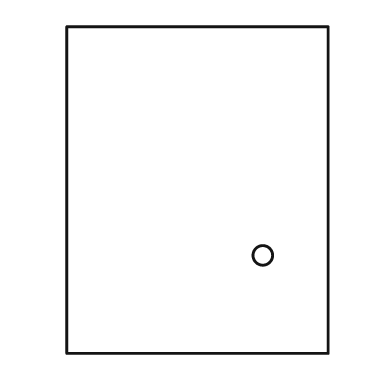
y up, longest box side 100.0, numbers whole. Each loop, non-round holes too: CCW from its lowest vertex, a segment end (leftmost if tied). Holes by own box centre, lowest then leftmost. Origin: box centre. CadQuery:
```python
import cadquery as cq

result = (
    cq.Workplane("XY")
    .moveTo(-40.0, -50.0)
    .lineTo(40.0, -50.0)
    .lineTo(40.0, 50.0)
    .lineTo(-40.0, 50.0)
    .close()
    .moveTo(20.0, -20.0)
    .circle(3.0)
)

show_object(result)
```